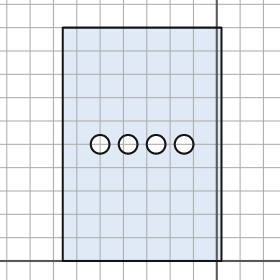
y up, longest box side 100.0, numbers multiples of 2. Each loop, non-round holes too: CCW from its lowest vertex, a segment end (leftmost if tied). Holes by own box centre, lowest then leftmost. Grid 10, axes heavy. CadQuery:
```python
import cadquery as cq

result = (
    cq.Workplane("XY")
    .moveTo(-66.0, 0.0)
    .lineTo(2.0, 0.0)
    .lineTo(2.0, 100.0)
    .lineTo(-66.0, 100.0)
    .close()
    .moveTo(-50.0, 50.0)
    .circle(4.0)
    .moveTo(-38.0, 50.0)
    .circle(4.0)
    .moveTo(-26.0, 50.0)
    .circle(4.0)
    .moveTo(-14.0, 50.0)
    .circle(4.0)
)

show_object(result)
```